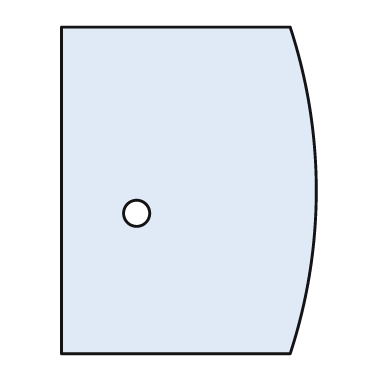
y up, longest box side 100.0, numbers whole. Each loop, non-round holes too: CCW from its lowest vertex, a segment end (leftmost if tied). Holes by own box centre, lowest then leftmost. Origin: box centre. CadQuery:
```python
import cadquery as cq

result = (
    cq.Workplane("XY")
    .moveTo(-39.0, -50.0)
    .lineTo(31.0, -50.0)
    .threePointArc((39.0, 0.0), (31.0, 50.0))
    .lineTo(-39.0, 50.0)
    .close()
    .moveTo(-16.0, -7.0)
    .circle(4.0)
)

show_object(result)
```